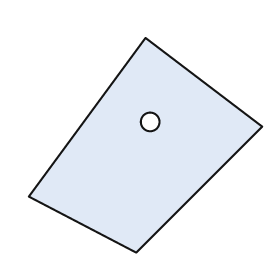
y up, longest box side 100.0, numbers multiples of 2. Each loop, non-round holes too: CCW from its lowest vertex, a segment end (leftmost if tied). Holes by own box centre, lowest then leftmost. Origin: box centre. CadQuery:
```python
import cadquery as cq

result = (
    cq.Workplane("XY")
    .moveTo(-4.0, -46.0)
    .lineTo(50.0, 8.0)
    .lineTo(0.0, 46.0)
    .lineTo(-50.0, -22.0)
    .close()
    .moveTo(2.0, 10.0)
    .circle(4.0)
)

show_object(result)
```